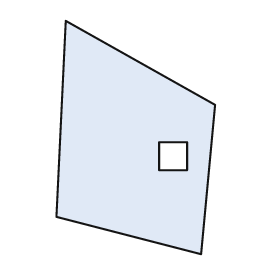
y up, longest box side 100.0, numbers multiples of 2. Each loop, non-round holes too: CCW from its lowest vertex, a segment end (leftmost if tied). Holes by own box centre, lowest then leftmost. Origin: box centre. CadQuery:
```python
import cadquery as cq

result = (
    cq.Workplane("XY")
    .moveTo(28.0, -50.0)
    .lineTo(34.0, 14.0)
    .lineTo(-30.0, 50.0)
    .lineTo(-34.0, -34.0)
    .close()
    .moveTo(10.0, -14.0)
    .lineTo(22.0, -14.0)
    .lineTo(22.0, -2.0)
    .lineTo(10.0, -2.0)
    .close()
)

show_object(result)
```